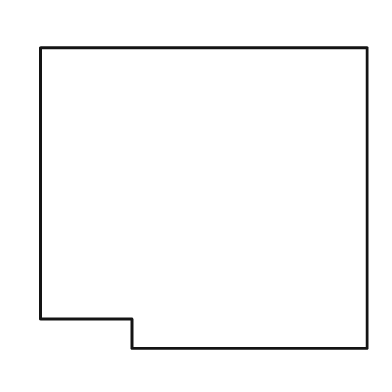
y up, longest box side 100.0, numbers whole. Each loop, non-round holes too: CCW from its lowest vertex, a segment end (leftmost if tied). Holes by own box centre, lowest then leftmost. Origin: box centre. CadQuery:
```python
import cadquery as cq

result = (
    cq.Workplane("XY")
    .moveTo(-22.0, -46.0)
    .lineTo(50.0, -46.0)
    .lineTo(50.0, 46.0)
    .lineTo(-50.0, 46.0)
    .lineTo(-50.0, -37.0)
    .lineTo(-22.0, -37.0)
    .close()
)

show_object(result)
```